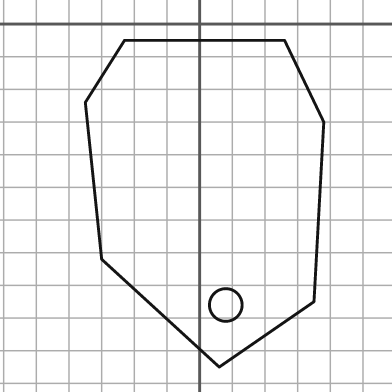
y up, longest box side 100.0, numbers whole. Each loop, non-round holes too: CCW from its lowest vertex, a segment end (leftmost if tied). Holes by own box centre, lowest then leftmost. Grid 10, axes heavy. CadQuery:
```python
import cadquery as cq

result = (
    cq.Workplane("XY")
    .moveTo(6.0, -105.0)
    .lineTo(35.0, -85.0)
    .lineTo(38.0, -30.0)
    .lineTo(26.0, -5.0)
    .lineTo(-23.0, -5.0)
    .lineTo(-35.0, -24.0)
    .lineTo(-30.0, -72.0)
    .close()
    .moveTo(8.0, -86.0)
    .circle(5.0)
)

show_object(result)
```